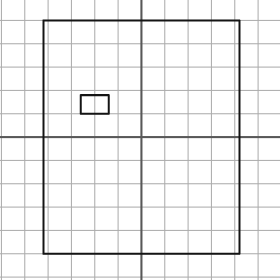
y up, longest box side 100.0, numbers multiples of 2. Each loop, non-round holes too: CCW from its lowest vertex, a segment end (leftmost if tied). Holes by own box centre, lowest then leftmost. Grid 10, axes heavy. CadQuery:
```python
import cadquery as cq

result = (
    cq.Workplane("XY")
    .moveTo(-42.0, -50.0)
    .lineTo(42.0, -50.0)
    .lineTo(42.0, 50.0)
    .lineTo(-42.0, 50.0)
    .close()
    .moveTo(-26.0, 10.0)
    .lineTo(-14.0, 10.0)
    .lineTo(-14.0, 18.0)
    .lineTo(-26.0, 18.0)
    .close()
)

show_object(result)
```